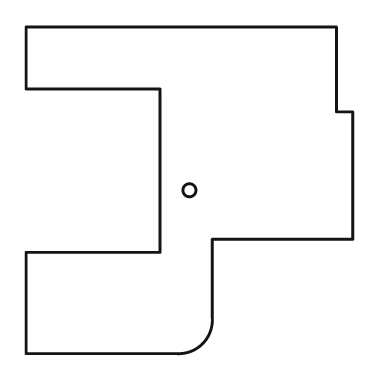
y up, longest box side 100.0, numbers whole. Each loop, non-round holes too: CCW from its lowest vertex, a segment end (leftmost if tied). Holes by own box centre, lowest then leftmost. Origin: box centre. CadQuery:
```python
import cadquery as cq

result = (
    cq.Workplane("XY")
    .moveTo(-50.0, -50.0)
    .lineTo(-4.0, -50.0)
    .threePointArc((4.0, -47.0), (7.0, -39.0))
    .lineTo(7.0, -15.0)
    .lineTo(50.0, -15.0)
    .lineTo(50.0, 24.0)
    .lineTo(45.0, 24.0)
    .lineTo(45.0, 50.0)
    .lineTo(-50.0, 50.0)
    .lineTo(-50.0, 31.0)
    .lineTo(-9.0, 31.0)
    .lineTo(-9.0, -19.0)
    .lineTo(-50.0, -19.0)
    .close()
    .moveTo(0.0, 0.0)
    .circle(2.0)
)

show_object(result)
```